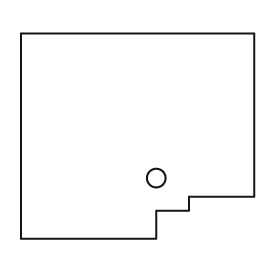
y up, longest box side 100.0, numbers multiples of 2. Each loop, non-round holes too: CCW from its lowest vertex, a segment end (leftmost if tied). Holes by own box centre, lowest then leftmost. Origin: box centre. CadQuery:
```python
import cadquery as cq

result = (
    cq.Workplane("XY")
    .moveTo(-50.0, -44.0)
    .lineTo(8.0, -44.0)
    .lineTo(8.0, -32.0)
    .lineTo(22.0, -32.0)
    .lineTo(22.0, -26.0)
    .lineTo(50.0, -26.0)
    .lineTo(50.0, 44.0)
    .lineTo(-50.0, 44.0)
    .close()
    .moveTo(8.0, -18.0)
    .circle(4.0)
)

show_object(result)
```